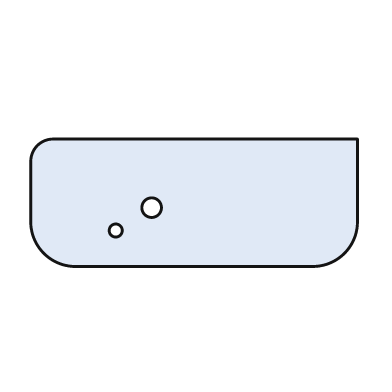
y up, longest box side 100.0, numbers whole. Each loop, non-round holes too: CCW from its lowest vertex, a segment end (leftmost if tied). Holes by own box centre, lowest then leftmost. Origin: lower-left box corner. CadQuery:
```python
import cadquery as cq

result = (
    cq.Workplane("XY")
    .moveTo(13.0, 0.0)
    .lineTo(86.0, 0.0)
    .threePointArc((96.0, 4.0), (100.0, 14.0))
    .lineTo(100.0, 39.0)
    .lineTo(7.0, 39.0)
    .threePointArc((2.0, 37.0), (0.0, 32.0))
    .lineTo(0.0, 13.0)
    .threePointArc((4.0, 4.0), (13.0, 0.0))
    .close()
    .moveTo(26.0, 11.0)
    .circle(2.0)
    .moveTo(37.0, 18.0)
    .circle(3.0)
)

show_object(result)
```